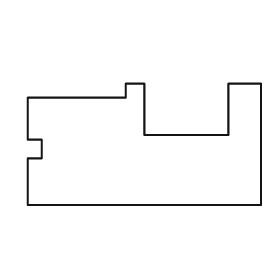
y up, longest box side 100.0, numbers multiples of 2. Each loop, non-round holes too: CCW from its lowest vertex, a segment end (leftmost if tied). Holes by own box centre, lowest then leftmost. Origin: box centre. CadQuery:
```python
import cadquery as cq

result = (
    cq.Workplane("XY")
    .moveTo(-50.0, -26.0)
    .lineTo(50.0, -26.0)
    .lineTo(50.0, 26.0)
    .lineTo(36.0, 26.0)
    .lineTo(36.0, 4.0)
    .lineTo(0.0, 4.0)
    .lineTo(0.0, 26.0)
    .lineTo(-8.0, 26.0)
    .lineTo(-8.0, 20.0)
    .lineTo(-50.0, 20.0)
    .lineTo(-50.0, 2.0)
    .lineTo(-44.0, 2.0)
    .lineTo(-44.0, -6.0)
    .lineTo(-50.0, -6.0)
    .close()
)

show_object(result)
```